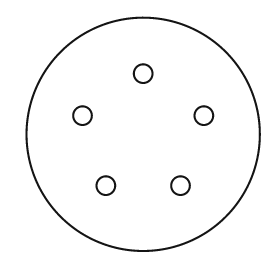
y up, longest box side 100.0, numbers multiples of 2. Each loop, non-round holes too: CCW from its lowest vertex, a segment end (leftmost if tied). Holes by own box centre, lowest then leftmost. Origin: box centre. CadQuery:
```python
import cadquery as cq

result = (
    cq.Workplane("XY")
    .moveTo(0.0, 0.0)
    .circle(50.0)
    .moveTo(-16.0, -22.0)
    .circle(4.0)
    .moveTo(16.0, -22.0)
    .circle(4.0)
    .moveTo(-26.0, 8.0)
    .circle(4.0)
    .moveTo(26.0, 8.0)
    .circle(4.0)
    .moveTo(0.0, 26.0)
    .circle(4.0)
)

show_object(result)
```